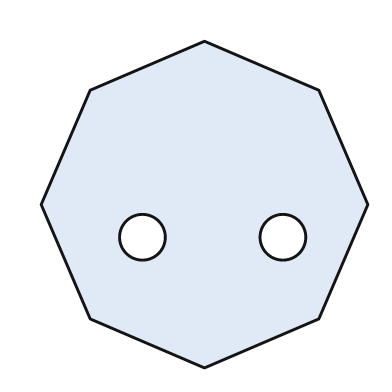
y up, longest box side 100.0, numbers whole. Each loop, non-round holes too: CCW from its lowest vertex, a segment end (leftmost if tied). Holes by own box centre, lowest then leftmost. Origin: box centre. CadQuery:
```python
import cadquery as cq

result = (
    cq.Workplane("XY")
    .moveTo(0.0, -50.0)
    .lineTo(35.0, -35.0)
    .lineTo(50.0, 0.0)
    .lineTo(35.0, 35.0)
    .lineTo(0.0, 50.0)
    .lineTo(-35.0, 35.0)
    .lineTo(-50.0, 0.0)
    .lineTo(-35.0, -35.0)
    .close()
    .moveTo(-19.0, -10.0)
    .circle(7.0)
    .moveTo(24.0, -10.0)
    .circle(7.0)
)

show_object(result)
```